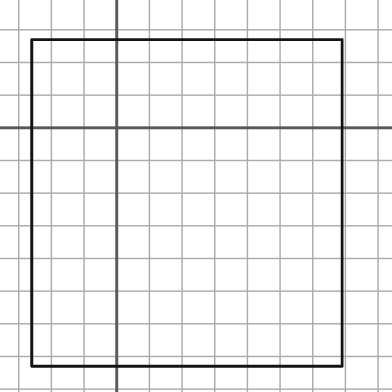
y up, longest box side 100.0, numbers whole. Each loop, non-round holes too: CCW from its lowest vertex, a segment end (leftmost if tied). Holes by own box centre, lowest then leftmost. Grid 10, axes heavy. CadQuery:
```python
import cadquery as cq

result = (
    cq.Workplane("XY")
    .moveTo(-26.0, -73.0)
    .lineTo(69.0, -73.0)
    .lineTo(69.0, 27.0)
    .lineTo(-26.0, 27.0)
    .close()
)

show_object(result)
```